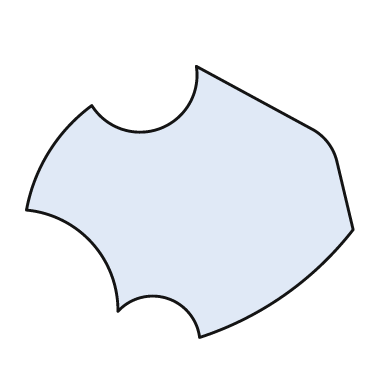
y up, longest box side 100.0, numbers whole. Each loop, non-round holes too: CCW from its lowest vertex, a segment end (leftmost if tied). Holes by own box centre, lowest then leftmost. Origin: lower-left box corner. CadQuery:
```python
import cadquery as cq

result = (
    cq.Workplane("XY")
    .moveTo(53.0, 0.0)
    .threePointArc((79.0, 13.0), (100.0, 33.0))
    .lineTo(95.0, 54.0)
    .threePointArc((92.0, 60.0), (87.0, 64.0))
    .lineTo(52.0, 83.0)
    .threePointArc((41.0, 64.0), (20.0, 71.0))
    .threePointArc((7.0, 57.0), (0.0, 39.0))
    .threePointArc((20.0, 29.0), (28.0, 8.0))
    .threePointArc((43.0, 12.0), (53.0, 0.0))
    .close()
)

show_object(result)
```